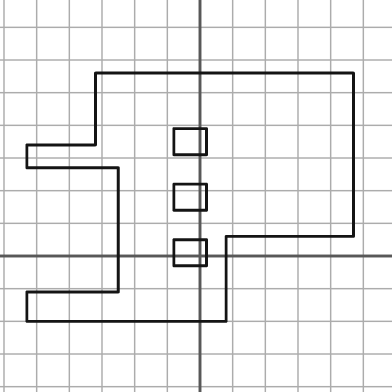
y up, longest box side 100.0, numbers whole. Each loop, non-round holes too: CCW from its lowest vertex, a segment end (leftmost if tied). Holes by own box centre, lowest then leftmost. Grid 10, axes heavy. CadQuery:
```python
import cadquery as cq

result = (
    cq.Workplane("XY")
    .moveTo(-53.0, -20.0)
    .lineTo(8.0, -20.0)
    .lineTo(8.0, 6.0)
    .lineTo(47.0, 6.0)
    .lineTo(47.0, 56.0)
    .lineTo(-32.0, 56.0)
    .lineTo(-32.0, 34.0)
    .lineTo(-53.0, 34.0)
    .lineTo(-53.0, 27.0)
    .lineTo(-25.0, 27.0)
    .lineTo(-25.0, -11.0)
    .lineTo(-53.0, -11.0)
    .close()
    .moveTo(-8.0, -3.0)
    .lineTo(2.0, -3.0)
    .lineTo(2.0, 5.0)
    .lineTo(-8.0, 5.0)
    .close()
    .moveTo(-8.0, 14.0)
    .lineTo(2.0, 14.0)
    .lineTo(2.0, 22.0)
    .lineTo(-8.0, 22.0)
    .close()
    .moveTo(-8.0, 31.0)
    .lineTo(2.0, 31.0)
    .lineTo(2.0, 39.0)
    .lineTo(-8.0, 39.0)
    .close()
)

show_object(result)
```